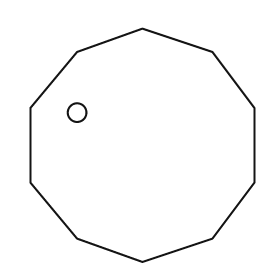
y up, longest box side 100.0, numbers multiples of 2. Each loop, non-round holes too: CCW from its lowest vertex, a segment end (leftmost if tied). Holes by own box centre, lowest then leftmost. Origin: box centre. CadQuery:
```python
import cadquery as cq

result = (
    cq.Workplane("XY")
    .moveTo(0.0, -50.0)
    .lineTo(30.0, -40.0)
    .lineTo(48.0, -16.0)
    .lineTo(48.0, 16.0)
    .lineTo(30.0, 40.0)
    .lineTo(0.0, 50.0)
    .lineTo(-28.0, 40.0)
    .lineTo(-48.0, 16.0)
    .lineTo(-48.0, -16.0)
    .lineTo(-28.0, -40.0)
    .close()
    .moveTo(-28.0, 14.0)
    .circle(4.0)
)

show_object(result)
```